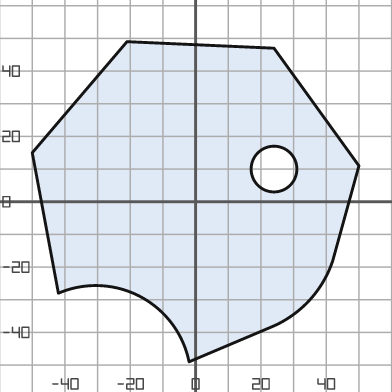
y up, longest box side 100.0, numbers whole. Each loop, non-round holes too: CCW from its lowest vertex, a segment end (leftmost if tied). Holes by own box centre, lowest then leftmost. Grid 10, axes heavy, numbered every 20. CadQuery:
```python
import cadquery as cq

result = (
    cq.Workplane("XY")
    .moveTo(-2.0, -49.0)
    .lineTo(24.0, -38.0)
    .threePointArc((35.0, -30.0), (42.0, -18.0))
    .lineTo(50.0, 11.0)
    .lineTo(24.0, 47.0)
    .lineTo(-21.0, 49.0)
    .lineTo(-50.0, 15.0)
    .lineTo(-42.0, -28.0)
    .threePointArc((-17.0, -29.0), (-2.0, -49.0))
    .close()
    .moveTo(24.0, 10.0)
    .circle(7.0)
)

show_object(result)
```